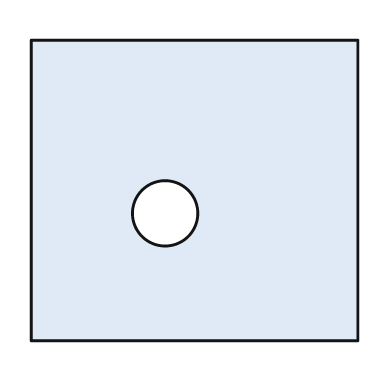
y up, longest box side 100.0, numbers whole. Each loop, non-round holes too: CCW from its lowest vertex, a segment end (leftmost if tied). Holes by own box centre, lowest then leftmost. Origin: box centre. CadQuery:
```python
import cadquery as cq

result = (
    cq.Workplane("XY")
    .moveTo(-50.0, -46.0)
    .lineTo(50.0, -46.0)
    .lineTo(50.0, 46.0)
    .lineTo(-50.0, 46.0)
    .close()
    .moveTo(-9.0, -7.0)
    .circle(10.0)
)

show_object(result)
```